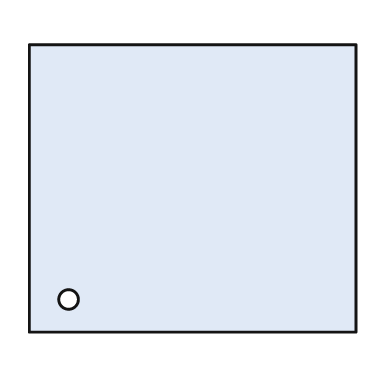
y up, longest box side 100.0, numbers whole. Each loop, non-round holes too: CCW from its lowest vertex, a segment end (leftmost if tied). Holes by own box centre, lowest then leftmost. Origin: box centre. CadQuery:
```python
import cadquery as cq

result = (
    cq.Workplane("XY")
    .moveTo(-50.0, -44.0)
    .lineTo(50.0, -44.0)
    .lineTo(50.0, 44.0)
    .lineTo(-50.0, 44.0)
    .close()
    .moveTo(-38.0, -34.0)
    .circle(3.0)
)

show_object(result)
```